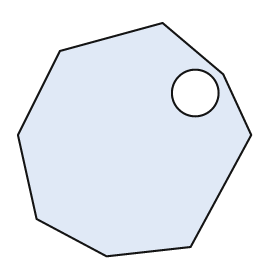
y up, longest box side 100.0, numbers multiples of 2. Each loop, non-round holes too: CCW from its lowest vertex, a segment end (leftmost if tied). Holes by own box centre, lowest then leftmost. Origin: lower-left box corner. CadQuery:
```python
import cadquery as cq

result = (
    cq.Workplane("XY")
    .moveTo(38.0, 0.0)
    .lineTo(74.0, 4.0)
    .lineTo(100.0, 52.0)
    .lineTo(88.0, 78.0)
    .lineTo(62.0, 100.0)
    .lineTo(18.0, 88.0)
    .lineTo(0.0, 52.0)
    .lineTo(8.0, 16.0)
    .close()
    .moveTo(76.0, 70.0)
    .circle(10.0)
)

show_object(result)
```